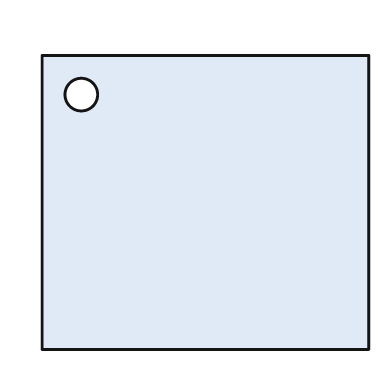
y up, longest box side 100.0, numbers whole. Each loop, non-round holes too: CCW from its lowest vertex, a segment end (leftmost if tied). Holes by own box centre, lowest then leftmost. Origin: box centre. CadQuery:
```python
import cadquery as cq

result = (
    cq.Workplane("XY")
    .moveTo(-50.0, -45.0)
    .lineTo(50.0, -45.0)
    .lineTo(50.0, 45.0)
    .lineTo(-50.0, 45.0)
    .close()
    .moveTo(-38.0, 33.0)
    .circle(5.0)
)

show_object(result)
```